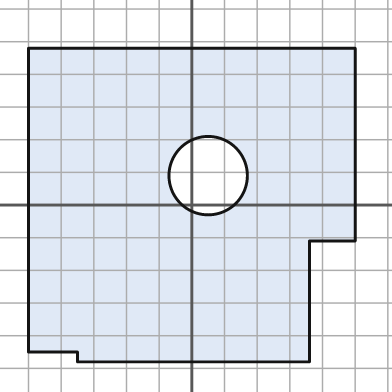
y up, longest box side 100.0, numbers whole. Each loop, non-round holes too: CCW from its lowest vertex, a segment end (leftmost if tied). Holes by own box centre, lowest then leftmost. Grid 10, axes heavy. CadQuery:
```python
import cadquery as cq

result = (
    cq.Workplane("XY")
    .moveTo(-35.0, -48.0)
    .lineTo(36.0, -48.0)
    .lineTo(36.0, -11.0)
    .lineTo(50.0, -11.0)
    .lineTo(50.0, 48.0)
    .lineTo(-50.0, 48.0)
    .lineTo(-50.0, -45.0)
    .lineTo(-35.0, -45.0)
    .close()
    .moveTo(5.0, 9.0)
    .circle(12.0)
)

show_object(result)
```